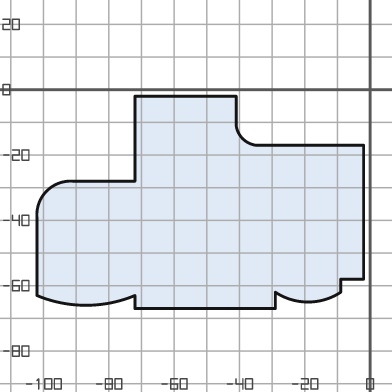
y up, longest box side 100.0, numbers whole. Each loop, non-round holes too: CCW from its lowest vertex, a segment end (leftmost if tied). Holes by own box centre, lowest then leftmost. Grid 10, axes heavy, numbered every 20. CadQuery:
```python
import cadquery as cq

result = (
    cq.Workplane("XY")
    .moveTo(-72.0, -67.0)
    .lineTo(-29.0, -67.0)
    .lineTo(-29.0, -62.0)
    .threePointArc((-19.0, -65.0), (-9.0, -62.0))
    .lineTo(-9.0, -58.0)
    .lineTo(-2.0, -58.0)
    .lineTo(-2.0, -17.0)
    .lineTo(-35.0, -17.0)
    .threePointArc((-39.0, -15.0), (-41.0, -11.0))
    .lineTo(-41.0, -2.0)
    .lineTo(-72.0, -2.0)
    .lineTo(-72.0, -28.0)
    .lineTo(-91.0, -28.0)
    .threePointArc((-99.0, -31.0), (-102.0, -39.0))
    .lineTo(-102.0, -63.0)
    .threePointArc((-87.0, -66.0), (-72.0, -63.0))
    .close()
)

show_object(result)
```